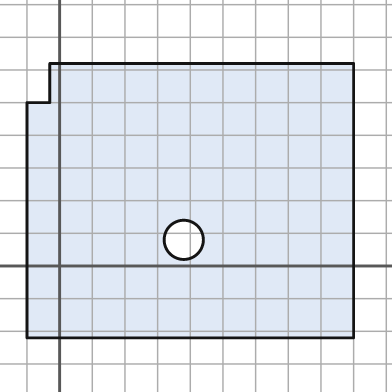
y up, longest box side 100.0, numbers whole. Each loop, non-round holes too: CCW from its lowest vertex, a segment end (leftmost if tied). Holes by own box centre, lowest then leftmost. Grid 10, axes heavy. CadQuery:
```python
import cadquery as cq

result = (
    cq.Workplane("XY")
    .moveTo(-10.0, -22.0)
    .lineTo(90.0, -22.0)
    .lineTo(90.0, 62.0)
    .lineTo(-3.0, 62.0)
    .lineTo(-3.0, 50.0)
    .lineTo(-10.0, 50.0)
    .close()
    .moveTo(38.0, 8.0)
    .circle(6.0)
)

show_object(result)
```